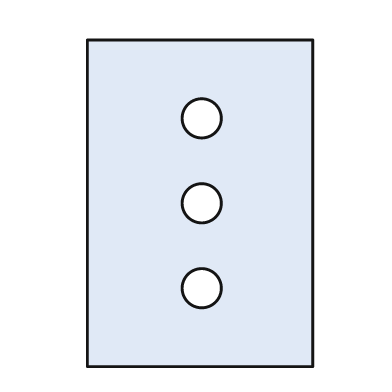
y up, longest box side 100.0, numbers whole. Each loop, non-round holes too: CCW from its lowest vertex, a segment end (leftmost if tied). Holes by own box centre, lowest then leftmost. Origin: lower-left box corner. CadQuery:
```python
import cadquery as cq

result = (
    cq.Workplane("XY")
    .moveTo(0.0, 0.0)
    .lineTo(69.0, 0.0)
    .lineTo(69.0, 100.0)
    .lineTo(0.0, 100.0)
    .close()
    .moveTo(35.0, 24.0)
    .circle(6.0)
    .moveTo(35.0, 50.0)
    .circle(6.0)
    .moveTo(35.0, 76.0)
    .circle(6.0)
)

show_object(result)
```